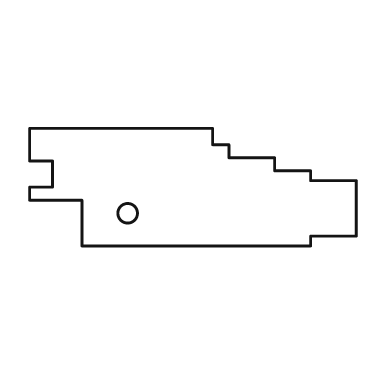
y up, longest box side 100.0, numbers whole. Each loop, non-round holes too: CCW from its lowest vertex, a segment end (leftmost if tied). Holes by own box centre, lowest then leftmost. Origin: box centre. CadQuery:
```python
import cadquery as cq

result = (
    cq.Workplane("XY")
    .moveTo(-34.0, -18.0)
    .lineTo(36.0, -18.0)
    .lineTo(36.0, -15.0)
    .lineTo(50.0, -15.0)
    .lineTo(50.0, 2.0)
    .lineTo(36.0, 2.0)
    .lineTo(36.0, 5.0)
    .lineTo(25.0, 5.0)
    .lineTo(25.0, 9.0)
    .lineTo(11.0, 9.0)
    .lineTo(11.0, 13.0)
    .lineTo(6.0, 13.0)
    .lineTo(6.0, 18.0)
    .lineTo(-50.0, 18.0)
    .lineTo(-50.0, 8.0)
    .lineTo(-43.0, 8.0)
    .lineTo(-43.0, 0.0)
    .lineTo(-50.0, 0.0)
    .lineTo(-50.0, -4.0)
    .lineTo(-34.0, -4.0)
    .close()
    .moveTo(-20.0, -8.0)
    .circle(3.0)
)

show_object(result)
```